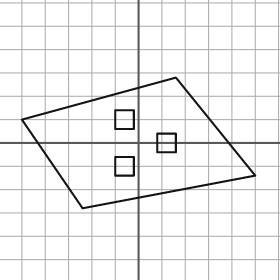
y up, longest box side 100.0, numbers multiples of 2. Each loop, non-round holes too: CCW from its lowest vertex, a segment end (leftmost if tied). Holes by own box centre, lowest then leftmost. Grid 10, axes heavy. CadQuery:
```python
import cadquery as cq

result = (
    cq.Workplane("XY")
    .moveTo(-24.0, -28.0)
    .lineTo(50.0, -14.0)
    .lineTo(16.0, 28.0)
    .lineTo(-50.0, 10.0)
    .close()
    .moveTo(-10.0, -14.0)
    .lineTo(-2.0, -14.0)
    .lineTo(-2.0, -6.0)
    .lineTo(-10.0, -6.0)
    .close()
    .moveTo(8.0, -4.0)
    .lineTo(16.0, -4.0)
    .lineTo(16.0, 4.0)
    .lineTo(8.0, 4.0)
    .close()
    .moveTo(-10.0, 6.0)
    .lineTo(-2.0, 6.0)
    .lineTo(-2.0, 14.0)
    .lineTo(-10.0, 14.0)
    .close()
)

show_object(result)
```